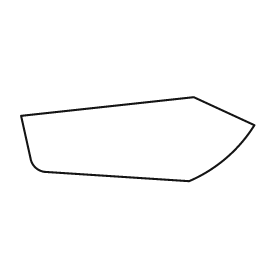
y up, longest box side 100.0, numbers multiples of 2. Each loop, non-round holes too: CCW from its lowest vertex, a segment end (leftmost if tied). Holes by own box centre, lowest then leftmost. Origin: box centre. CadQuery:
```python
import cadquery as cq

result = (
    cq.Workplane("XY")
    .moveTo(22.0, -18.0)
    .threePointArc((38.0, -8.0), (50.0, 6.0))
    .lineTo(24.0, 18.0)
    .lineTo(-50.0, 10.0)
    .lineTo(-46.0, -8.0)
    .threePointArc((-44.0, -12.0), (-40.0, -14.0))
    .close()
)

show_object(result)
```